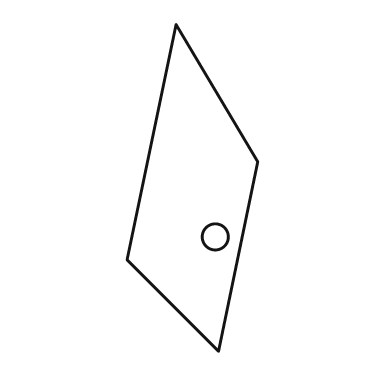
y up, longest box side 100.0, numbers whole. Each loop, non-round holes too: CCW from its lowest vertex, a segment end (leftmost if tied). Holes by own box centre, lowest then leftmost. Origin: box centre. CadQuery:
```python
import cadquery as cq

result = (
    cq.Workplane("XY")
    .moveTo(8.0, -50.0)
    .lineTo(20.0, 8.0)
    .lineTo(-5.0, 50.0)
    .lineTo(-20.0, -22.0)
    .close()
    .moveTo(7.0, -15.0)
    .circle(4.0)
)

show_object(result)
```